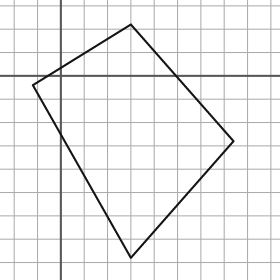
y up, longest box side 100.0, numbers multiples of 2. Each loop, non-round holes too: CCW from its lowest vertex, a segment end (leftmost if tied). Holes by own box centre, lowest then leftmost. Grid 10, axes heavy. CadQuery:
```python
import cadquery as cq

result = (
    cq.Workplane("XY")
    .moveTo(30.0, -78.0)
    .lineTo(74.0, -28.0)
    .lineTo(30.0, 22.0)
    .lineTo(-12.0, -4.0)
    .close()
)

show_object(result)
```